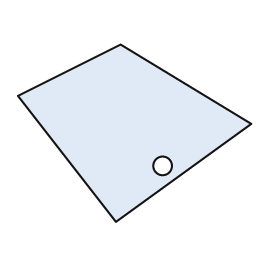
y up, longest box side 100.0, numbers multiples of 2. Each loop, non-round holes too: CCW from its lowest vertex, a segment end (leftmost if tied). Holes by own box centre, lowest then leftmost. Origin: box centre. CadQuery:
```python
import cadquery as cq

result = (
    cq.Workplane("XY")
    .moveTo(-8.0, -38.0)
    .lineTo(50.0, 4.0)
    .lineTo(-6.0, 38.0)
    .lineTo(-50.0, 16.0)
    .close()
    .moveTo(12.0, -14.0)
    .circle(4.0)
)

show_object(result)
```